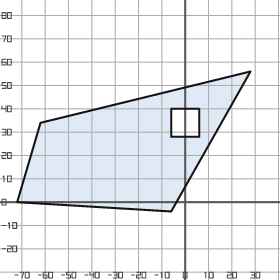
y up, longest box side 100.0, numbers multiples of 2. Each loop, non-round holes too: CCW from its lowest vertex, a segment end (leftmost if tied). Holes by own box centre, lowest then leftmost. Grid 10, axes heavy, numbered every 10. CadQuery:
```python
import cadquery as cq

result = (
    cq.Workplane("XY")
    .moveTo(-6.0, -4.0)
    .lineTo(28.0, 56.0)
    .lineTo(-62.0, 34.0)
    .lineTo(-72.0, 0.0)
    .close()
    .moveTo(-6.0, 28.0)
    .lineTo(6.0, 28.0)
    .lineTo(6.0, 40.0)
    .lineTo(-6.0, 40.0)
    .close()
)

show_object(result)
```